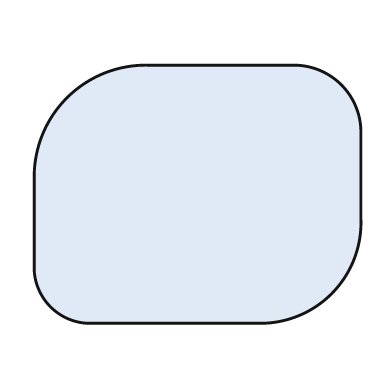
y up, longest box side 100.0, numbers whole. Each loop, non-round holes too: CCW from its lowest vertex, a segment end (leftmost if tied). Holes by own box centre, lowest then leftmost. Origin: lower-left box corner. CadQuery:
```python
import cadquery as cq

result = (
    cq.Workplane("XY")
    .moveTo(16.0, 0.0)
    .lineTo(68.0, 0.0)
    .threePointArc((91.0, 9.0), (100.0, 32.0))
    .lineTo(100.0, 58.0)
    .threePointArc((94.0, 73.0), (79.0, 79.0))
    .lineTo(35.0, 79.0)
    .threePointArc((10.0, 69.0), (0.0, 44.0))
    .lineTo(0.0, 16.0)
    .threePointArc((5.0, 5.0), (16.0, 0.0))
    .close()
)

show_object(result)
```